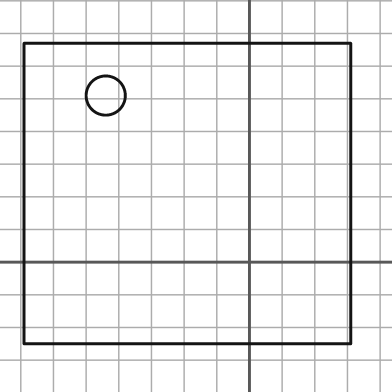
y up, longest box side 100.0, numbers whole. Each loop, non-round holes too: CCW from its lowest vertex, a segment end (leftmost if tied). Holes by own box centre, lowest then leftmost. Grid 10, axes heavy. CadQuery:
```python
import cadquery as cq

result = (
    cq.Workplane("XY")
    .moveTo(-69.0, -25.0)
    .lineTo(31.0, -25.0)
    .lineTo(31.0, 67.0)
    .lineTo(-69.0, 67.0)
    .close()
    .moveTo(-44.0, 51.0)
    .circle(6.0)
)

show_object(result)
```